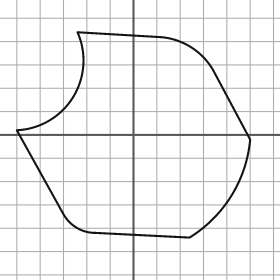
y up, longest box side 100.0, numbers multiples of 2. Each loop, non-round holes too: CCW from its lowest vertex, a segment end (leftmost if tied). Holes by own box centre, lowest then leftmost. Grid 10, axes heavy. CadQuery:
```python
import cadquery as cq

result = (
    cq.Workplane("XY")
    .moveTo(24.0, -44.0)
    .threePointArc((42.0, -26.0), (50.0, -2.0))
    .lineTo(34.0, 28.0)
    .threePointArc((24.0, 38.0), (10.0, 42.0))
    .lineTo(-24.0, 44.0)
    .threePointArc((-26.0, 16.0), (-50.0, 2.0))
    .lineTo(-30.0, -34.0)
    .threePointArc((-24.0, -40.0), (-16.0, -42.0))
    .close()
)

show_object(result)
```